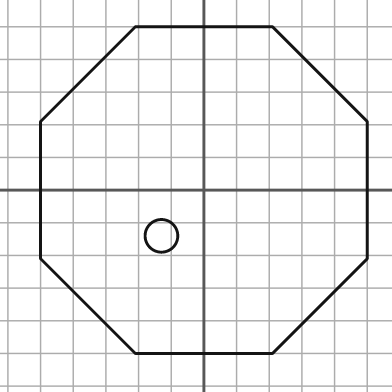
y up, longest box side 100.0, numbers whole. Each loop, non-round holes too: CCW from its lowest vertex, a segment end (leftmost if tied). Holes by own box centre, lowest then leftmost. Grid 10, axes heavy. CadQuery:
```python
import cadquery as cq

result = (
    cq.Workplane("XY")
    .moveTo(-21.0, -50.0)
    .lineTo(21.0, -50.0)
    .lineTo(50.0, -21.0)
    .lineTo(50.0, 21.0)
    .lineTo(21.0, 50.0)
    .lineTo(-21.0, 50.0)
    .lineTo(-50.0, 21.0)
    .lineTo(-50.0, -21.0)
    .close()
    .moveTo(-13.0, -14.0)
    .circle(5.0)
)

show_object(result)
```